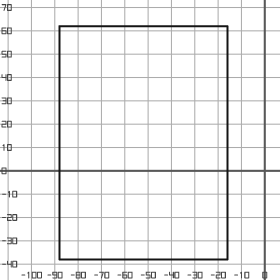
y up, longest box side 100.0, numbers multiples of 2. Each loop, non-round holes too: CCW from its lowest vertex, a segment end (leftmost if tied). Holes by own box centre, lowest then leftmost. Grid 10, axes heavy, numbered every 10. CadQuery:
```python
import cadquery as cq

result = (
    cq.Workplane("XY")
    .moveTo(-88.0, -38.0)
    .lineTo(-16.0, -38.0)
    .lineTo(-16.0, 62.0)
    .lineTo(-88.0, 62.0)
    .close()
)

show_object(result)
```